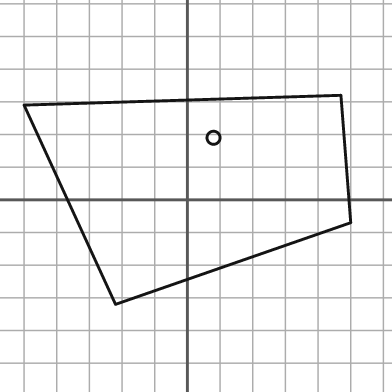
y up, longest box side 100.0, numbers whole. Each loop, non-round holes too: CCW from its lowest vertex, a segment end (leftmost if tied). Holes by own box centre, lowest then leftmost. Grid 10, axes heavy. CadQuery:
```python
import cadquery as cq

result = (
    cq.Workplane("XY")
    .moveTo(-22.0, -32.0)
    .lineTo(50.0, -7.0)
    .lineTo(47.0, 32.0)
    .lineTo(-50.0, 29.0)
    .close()
    .moveTo(8.0, 19.0)
    .circle(2.0)
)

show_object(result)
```